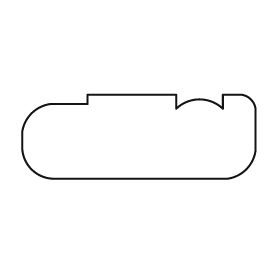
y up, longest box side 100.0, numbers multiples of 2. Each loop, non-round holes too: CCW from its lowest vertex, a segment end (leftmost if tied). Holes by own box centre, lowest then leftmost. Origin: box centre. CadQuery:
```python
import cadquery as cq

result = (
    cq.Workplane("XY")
    .moveTo(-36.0, -18.0)
    .lineTo(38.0, -18.0)
    .threePointArc((46.0, -14.0), (50.0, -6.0))
    .lineTo(50.0, 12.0)
    .threePointArc((48.0, 16.0), (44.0, 18.0))
    .lineTo(36.0, 18.0)
    .lineTo(36.0, 12.0)
    .threePointArc((26.0, 16.0), (16.0, 12.0))
    .lineTo(16.0, 18.0)
    .lineTo(-22.0, 18.0)
    .lineTo(-22.0, 14.0)
    .lineTo(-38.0, 14.0)
    .threePointArc((-46.0, 10.0), (-50.0, 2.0))
    .lineTo(-50.0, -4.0)
    .threePointArc((-46.0, -14.0), (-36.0, -18.0))
    .close()
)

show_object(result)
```